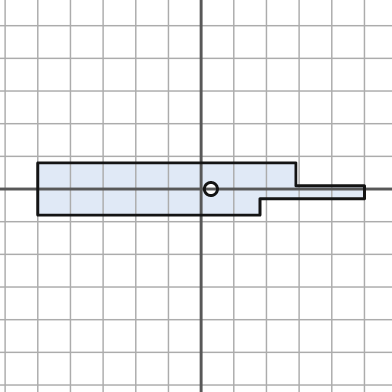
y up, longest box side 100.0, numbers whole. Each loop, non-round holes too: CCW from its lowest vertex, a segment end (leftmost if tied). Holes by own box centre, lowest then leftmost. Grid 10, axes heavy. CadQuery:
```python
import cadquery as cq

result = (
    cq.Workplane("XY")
    .moveTo(-50.0, -8.0)
    .lineTo(18.0, -8.0)
    .lineTo(18.0, -3.0)
    .lineTo(50.0, -3.0)
    .lineTo(50.0, 1.0)
    .lineTo(29.0, 1.0)
    .lineTo(29.0, 8.0)
    .lineTo(-50.0, 8.0)
    .close()
    .moveTo(3.0, 0.0)
    .circle(2.0)
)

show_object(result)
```